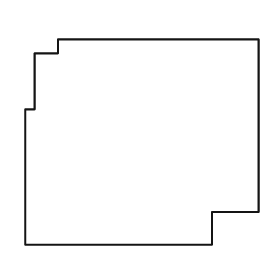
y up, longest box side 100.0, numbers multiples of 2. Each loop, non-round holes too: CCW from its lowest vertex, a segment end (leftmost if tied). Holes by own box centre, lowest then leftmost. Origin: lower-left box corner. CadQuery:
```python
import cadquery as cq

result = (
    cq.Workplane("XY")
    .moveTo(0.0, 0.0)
    .lineTo(80.0, 0.0)
    .lineTo(80.0, 14.0)
    .lineTo(100.0, 14.0)
    .lineTo(100.0, 88.0)
    .lineTo(14.0, 88.0)
    .lineTo(14.0, 82.0)
    .lineTo(4.0, 82.0)
    .lineTo(4.0, 58.0)
    .lineTo(0.0, 58.0)
    .close()
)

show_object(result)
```